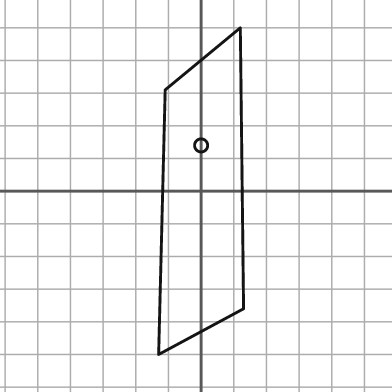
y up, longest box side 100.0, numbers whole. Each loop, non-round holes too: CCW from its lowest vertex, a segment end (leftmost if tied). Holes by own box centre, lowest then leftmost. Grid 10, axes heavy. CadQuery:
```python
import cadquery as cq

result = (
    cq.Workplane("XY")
    .moveTo(-13.0, -50.0)
    .lineTo(13.0, -36.0)
    .lineTo(12.0, 50.0)
    .lineTo(-11.0, 31.0)
    .close()
    .moveTo(0.0, 14.0)
    .circle(2.0)
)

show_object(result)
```